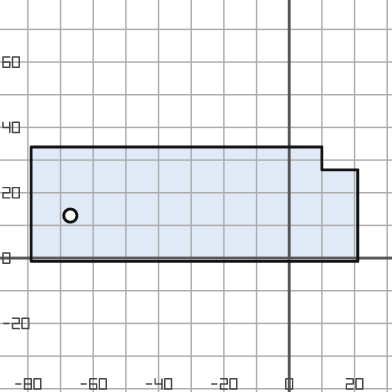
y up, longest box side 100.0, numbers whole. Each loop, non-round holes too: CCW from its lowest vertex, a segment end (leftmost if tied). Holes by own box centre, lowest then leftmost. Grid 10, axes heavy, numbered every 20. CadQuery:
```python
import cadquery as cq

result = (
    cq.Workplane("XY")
    .moveTo(-79.0, -1.0)
    .lineTo(21.0, -1.0)
    .lineTo(21.0, 27.0)
    .lineTo(10.0, 27.0)
    .lineTo(10.0, 34.0)
    .lineTo(-79.0, 34.0)
    .close()
    .moveTo(-67.0, 13.0)
    .circle(2.0)
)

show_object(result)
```